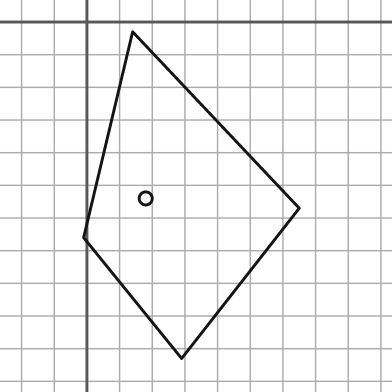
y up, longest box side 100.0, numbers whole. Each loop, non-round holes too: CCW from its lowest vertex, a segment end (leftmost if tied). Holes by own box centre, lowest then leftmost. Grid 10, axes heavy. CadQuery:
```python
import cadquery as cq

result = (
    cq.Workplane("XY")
    .moveTo(29.0, -103.0)
    .lineTo(65.0, -57.0)
    .lineTo(14.0, -3.0)
    .lineTo(-1.0, -66.0)
    .close()
    .moveTo(18.0, -54.0)
    .circle(2.0)
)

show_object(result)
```